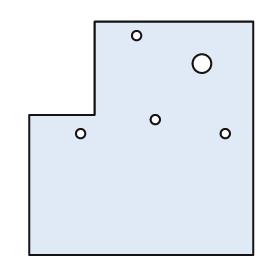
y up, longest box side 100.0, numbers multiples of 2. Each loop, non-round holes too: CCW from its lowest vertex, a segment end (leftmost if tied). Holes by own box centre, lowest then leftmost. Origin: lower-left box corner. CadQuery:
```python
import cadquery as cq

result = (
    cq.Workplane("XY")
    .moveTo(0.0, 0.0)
    .lineTo(96.0, 0.0)
    .lineTo(96.0, 100.0)
    .lineTo(28.0, 100.0)
    .lineTo(28.0, 60.0)
    .lineTo(0.0, 60.0)
    .close()
    .moveTo(22.0, 52.0)
    .circle(2.0)
    .moveTo(84.0, 52.0)
    .circle(2.0)
    .moveTo(54.0, 58.0)
    .circle(2.0)
    .moveTo(74.0, 82.0)
    .circle(4.0)
    .moveTo(46.0, 94.0)
    .circle(2.0)
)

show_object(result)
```